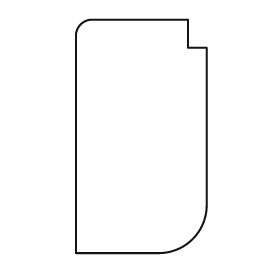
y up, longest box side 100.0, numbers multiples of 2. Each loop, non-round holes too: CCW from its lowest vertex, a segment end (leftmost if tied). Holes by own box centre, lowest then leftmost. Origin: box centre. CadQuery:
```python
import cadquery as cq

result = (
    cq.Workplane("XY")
    .moveTo(-28.0, -50.0)
    .lineTo(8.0, -50.0)
    .threePointArc((22.0, -44.0), (28.0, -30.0))
    .lineTo(28.0, 38.0)
    .lineTo(20.0, 38.0)
    .lineTo(20.0, 50.0)
    .lineTo(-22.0, 50.0)
    .threePointArc((-26.0, 48.0), (-28.0, 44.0))
    .close()
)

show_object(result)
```